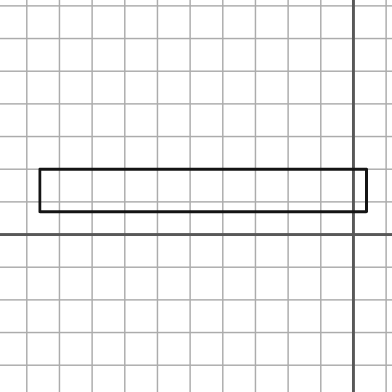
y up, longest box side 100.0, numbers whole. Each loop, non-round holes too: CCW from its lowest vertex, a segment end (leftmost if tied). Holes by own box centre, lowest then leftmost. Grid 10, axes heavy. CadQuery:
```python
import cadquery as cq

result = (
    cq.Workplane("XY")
    .moveTo(-96.0, 7.0)
    .lineTo(4.0, 7.0)
    .lineTo(4.0, 20.0)
    .lineTo(-96.0, 20.0)
    .close()
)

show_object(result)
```